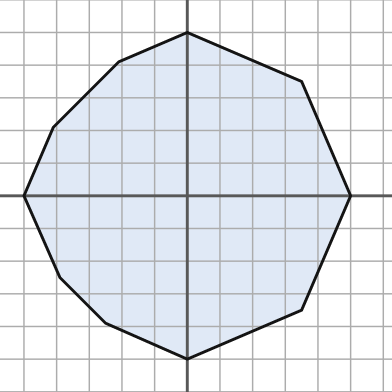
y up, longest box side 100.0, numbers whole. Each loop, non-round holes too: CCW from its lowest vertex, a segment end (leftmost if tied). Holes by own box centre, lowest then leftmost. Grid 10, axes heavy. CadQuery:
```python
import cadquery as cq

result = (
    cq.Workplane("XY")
    .moveTo(0.0, -50.0)
    .lineTo(35.0, -35.0)
    .lineTo(50.0, 0.0)
    .lineTo(35.0, 35.0)
    .lineTo(0.0, 50.0)
    .lineTo(-21.0, 41.0)
    .lineTo(-41.0, 21.0)
    .lineTo(-50.0, 0.0)
    .lineTo(-39.0, -25.0)
    .lineTo(-25.0, -39.0)
    .close()
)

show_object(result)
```